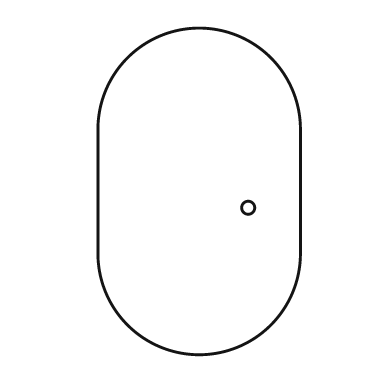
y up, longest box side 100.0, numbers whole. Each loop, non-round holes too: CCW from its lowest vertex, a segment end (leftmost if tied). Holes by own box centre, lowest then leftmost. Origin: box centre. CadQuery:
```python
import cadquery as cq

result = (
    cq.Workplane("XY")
    .moveTo(-31.0, -19.0)
    .threePointArc((0.0, -50.0), (31.0, -19.0))
    .lineTo(31.0, 19.0)
    .threePointArc((0.0, 50.0), (-31.0, 19.0))
    .close()
    .moveTo(15.0, -5.0)
    .circle(2.0)
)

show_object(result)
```